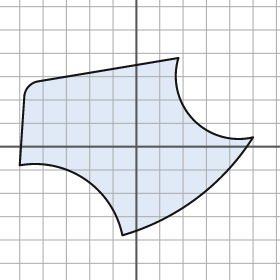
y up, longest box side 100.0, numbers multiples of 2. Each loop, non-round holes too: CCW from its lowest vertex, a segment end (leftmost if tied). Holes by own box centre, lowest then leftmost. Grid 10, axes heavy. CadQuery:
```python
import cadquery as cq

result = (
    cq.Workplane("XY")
    .moveTo(-6.0, -38.0)
    .threePointArc((26.0, -22.0), (50.0, 4.0))
    .threePointArc((24.0, 12.0), (18.0, 38.0))
    .lineTo(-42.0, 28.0)
    .threePointArc((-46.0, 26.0), (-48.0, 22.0))
    .lineTo(-50.0, -8.0)
    .threePointArc((-22.0, -14.0), (-6.0, -38.0))
    .close()
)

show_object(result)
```